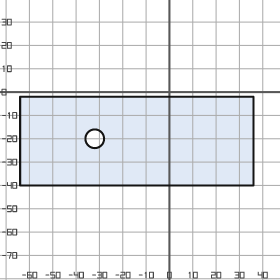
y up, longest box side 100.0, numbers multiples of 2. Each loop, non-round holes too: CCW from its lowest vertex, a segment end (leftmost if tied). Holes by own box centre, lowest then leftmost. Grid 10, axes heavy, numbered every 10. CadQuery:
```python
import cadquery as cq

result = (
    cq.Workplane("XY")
    .moveTo(-64.0, -40.0)
    .lineTo(36.0, -40.0)
    .lineTo(36.0, -2.0)
    .lineTo(-64.0, -2.0)
    .close()
    .moveTo(-32.0, -20.0)
    .circle(4.0)
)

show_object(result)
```